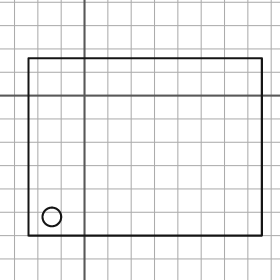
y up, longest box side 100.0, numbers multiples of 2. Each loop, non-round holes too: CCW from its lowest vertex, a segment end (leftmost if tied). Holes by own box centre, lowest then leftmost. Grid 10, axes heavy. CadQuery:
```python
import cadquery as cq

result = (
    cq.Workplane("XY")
    .moveTo(-24.0, -60.0)
    .lineTo(76.0, -60.0)
    .lineTo(76.0, 16.0)
    .lineTo(-24.0, 16.0)
    .close()
    .moveTo(-14.0, -52.0)
    .circle(4.0)
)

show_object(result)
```